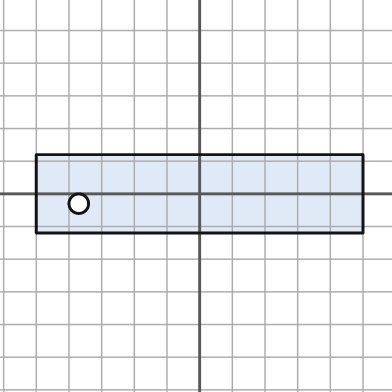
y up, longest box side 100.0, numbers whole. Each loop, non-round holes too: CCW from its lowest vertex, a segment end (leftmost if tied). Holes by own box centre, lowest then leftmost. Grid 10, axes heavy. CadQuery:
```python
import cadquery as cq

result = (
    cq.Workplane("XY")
    .moveTo(-50.0, -12.0)
    .lineTo(50.0, -12.0)
    .lineTo(50.0, 12.0)
    .lineTo(-50.0, 12.0)
    .close()
    .moveTo(-37.0, -3.0)
    .circle(3.0)
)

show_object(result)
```